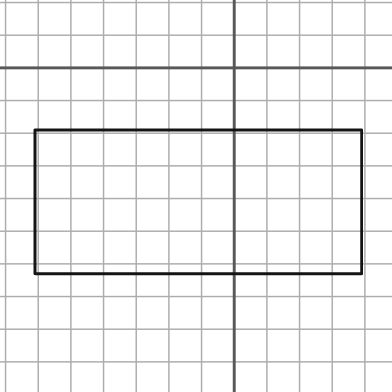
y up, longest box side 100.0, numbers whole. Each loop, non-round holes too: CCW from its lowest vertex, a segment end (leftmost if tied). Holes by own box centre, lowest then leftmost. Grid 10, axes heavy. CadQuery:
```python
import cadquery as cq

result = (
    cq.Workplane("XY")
    .moveTo(-61.0, -63.0)
    .lineTo(39.0, -63.0)
    .lineTo(39.0, -19.0)
    .lineTo(-61.0, -19.0)
    .close()
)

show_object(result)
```